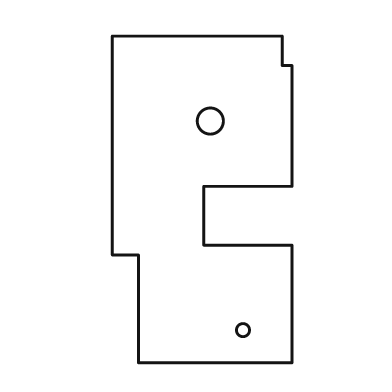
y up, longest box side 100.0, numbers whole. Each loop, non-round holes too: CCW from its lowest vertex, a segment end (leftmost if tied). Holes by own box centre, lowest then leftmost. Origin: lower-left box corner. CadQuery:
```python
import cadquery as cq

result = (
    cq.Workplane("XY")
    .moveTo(8.0, 0.0)
    .lineTo(55.0, 0.0)
    .lineTo(55.0, 36.0)
    .lineTo(28.0, 36.0)
    .lineTo(28.0, 54.0)
    .lineTo(55.0, 54.0)
    .lineTo(55.0, 91.0)
    .lineTo(52.0, 91.0)
    .lineTo(52.0, 100.0)
    .lineTo(0.0, 100.0)
    .lineTo(0.0, 33.0)
    .lineTo(8.0, 33.0)
    .close()
    .moveTo(40.0, 10.0)
    .circle(2.0)
    .moveTo(30.0, 74.0)
    .circle(4.0)
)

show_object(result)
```